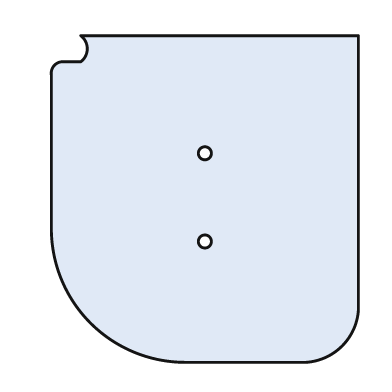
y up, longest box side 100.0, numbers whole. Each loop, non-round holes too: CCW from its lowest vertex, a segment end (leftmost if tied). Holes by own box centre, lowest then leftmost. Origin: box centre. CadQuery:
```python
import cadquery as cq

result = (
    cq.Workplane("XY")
    .moveTo(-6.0, -50.0)
    .lineTo(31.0, -50.0)
    .threePointArc((42.0, -45.0), (47.0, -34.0))
    .lineTo(47.0, 50.0)
    .lineTo(-38.0, 50.0)
    .threePointArc((-36.0, 46.0), (-38.0, 42.0))
    .lineTo(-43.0, 42.0)
    .threePointArc((-46.0, 41.0), (-47.0, 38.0))
    .lineTo(-47.0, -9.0)
    .threePointArc((-35.0, -38.0), (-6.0, -50.0))
    .close()
    .moveTo(0.0, -13.0)
    .circle(2.0)
    .moveTo(0.0, 14.0)
    .circle(2.0)
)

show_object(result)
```